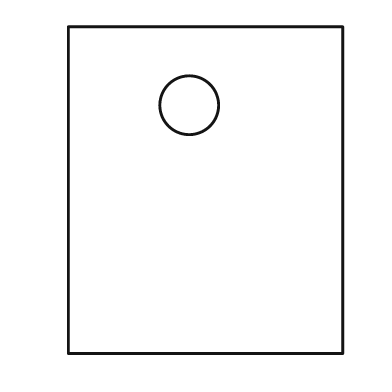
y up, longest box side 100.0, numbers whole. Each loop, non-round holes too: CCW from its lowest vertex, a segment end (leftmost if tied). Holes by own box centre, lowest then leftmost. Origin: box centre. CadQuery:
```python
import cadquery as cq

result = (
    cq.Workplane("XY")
    .moveTo(-42.0, -50.0)
    .lineTo(42.0, -50.0)
    .lineTo(42.0, 50.0)
    .lineTo(-42.0, 50.0)
    .close()
    .moveTo(-5.0, 26.0)
    .circle(9.0)
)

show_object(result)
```